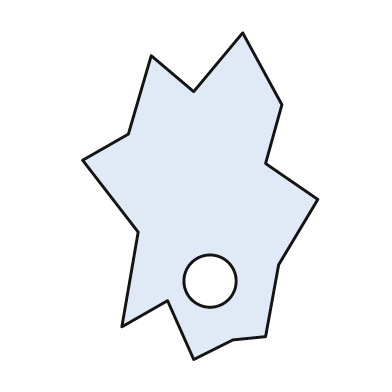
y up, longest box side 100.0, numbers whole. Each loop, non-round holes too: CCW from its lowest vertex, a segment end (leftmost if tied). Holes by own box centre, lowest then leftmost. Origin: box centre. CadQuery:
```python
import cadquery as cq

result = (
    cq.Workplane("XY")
    .moveTo(-2.0, -50.0)
    .lineTo(10.0, -44.0)
    .lineTo(20.0, -43.0)
    .lineTo(24.0, -21.0)
    .lineTo(36.0, -1.0)
    .lineTo(20.0, 10.0)
    .lineTo(25.0, 28.0)
    .lineTo(13.0, 50.0)
    .lineTo(-2.0, 32.0)
    .lineTo(-15.0, 43.0)
    .lineTo(-22.0, 19.0)
    .lineTo(-36.0, 11.0)
    .lineTo(-19.0, -11.0)
    .lineTo(-24.0, -40.0)
    .lineTo(-10.0, -32.0)
    .close()
    .moveTo(3.0, -26.0)
    .circle(8.0)
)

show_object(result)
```